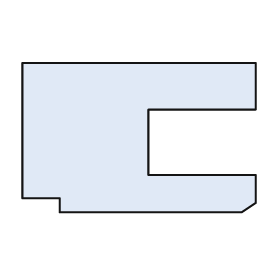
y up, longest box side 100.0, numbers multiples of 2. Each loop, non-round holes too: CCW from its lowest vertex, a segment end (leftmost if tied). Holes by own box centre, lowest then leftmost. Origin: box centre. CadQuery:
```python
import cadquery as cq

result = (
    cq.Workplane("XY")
    .moveTo(-34.0, -32.0)
    .lineTo(44.0, -32.0)
    .lineTo(50.0, -28.0)
    .lineTo(50.0, -16.0)
    .lineTo(4.0, -16.0)
    .lineTo(4.0, 12.0)
    .lineTo(50.0, 12.0)
    .lineTo(50.0, 32.0)
    .lineTo(-50.0, 32.0)
    .lineTo(-50.0, -26.0)
    .lineTo(-34.0, -26.0)
    .close()
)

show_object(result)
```